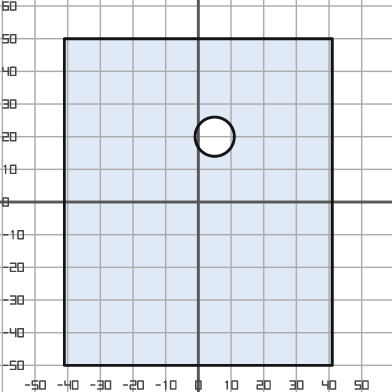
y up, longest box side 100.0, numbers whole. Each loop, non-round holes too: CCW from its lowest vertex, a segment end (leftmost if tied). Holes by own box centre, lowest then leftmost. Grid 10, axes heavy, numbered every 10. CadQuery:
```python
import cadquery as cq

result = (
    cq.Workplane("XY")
    .moveTo(-41.0, -50.0)
    .lineTo(41.0, -50.0)
    .lineTo(41.0, 50.0)
    .lineTo(-41.0, 50.0)
    .close()
    .moveTo(5.0, 20.0)
    .circle(6.0)
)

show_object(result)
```